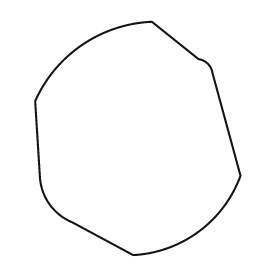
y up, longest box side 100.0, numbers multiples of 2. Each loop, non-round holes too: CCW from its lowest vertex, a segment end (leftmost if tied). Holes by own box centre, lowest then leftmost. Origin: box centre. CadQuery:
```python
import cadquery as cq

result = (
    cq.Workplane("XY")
    .moveTo(-2.0, -50.0)
    .threePointArc((26.0, -40.0), (44.0, -16.0))
    .lineTo(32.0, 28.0)
    .threePointArc((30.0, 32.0), (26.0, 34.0))
    .lineTo(6.0, 50.0)
    .threePointArc((-24.0, 40.0), (-44.0, 16.0))
    .lineTo(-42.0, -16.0)
    .threePointArc((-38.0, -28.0), (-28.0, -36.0))
    .close()
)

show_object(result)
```